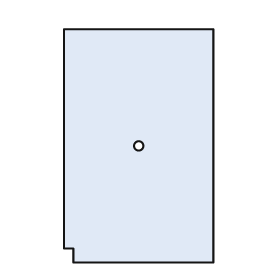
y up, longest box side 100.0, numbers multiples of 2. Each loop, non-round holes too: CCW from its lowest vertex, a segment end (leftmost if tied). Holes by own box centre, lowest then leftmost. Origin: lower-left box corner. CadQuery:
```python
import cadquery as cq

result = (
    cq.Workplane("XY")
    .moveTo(4.0, 0.0)
    .lineTo(64.0, 0.0)
    .lineTo(64.0, 100.0)
    .lineTo(0.0, 100.0)
    .lineTo(0.0, 6.0)
    .lineTo(4.0, 6.0)
    .close()
    .moveTo(32.0, 50.0)
    .circle(2.0)
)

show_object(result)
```